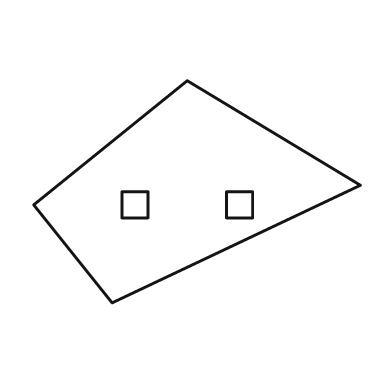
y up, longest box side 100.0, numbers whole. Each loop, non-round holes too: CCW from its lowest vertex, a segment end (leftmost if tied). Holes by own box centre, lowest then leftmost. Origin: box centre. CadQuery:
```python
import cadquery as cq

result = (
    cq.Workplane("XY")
    .moveTo(-26.0, -34.0)
    .lineTo(50.0, 2.0)
    .lineTo(-3.0, 34.0)
    .lineTo(-50.0, -4.0)
    .close()
    .moveTo(-23.0, -8.0)
    .lineTo(-15.0, -8.0)
    .lineTo(-15.0, 0.0)
    .lineTo(-23.0, 0.0)
    .close()
    .moveTo(9.0, -8.0)
    .lineTo(17.0, -8.0)
    .lineTo(17.0, 0.0)
    .lineTo(9.0, 0.0)
    .close()
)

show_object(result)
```